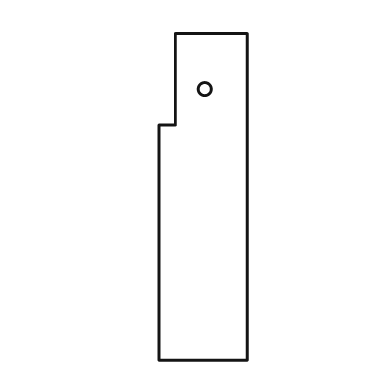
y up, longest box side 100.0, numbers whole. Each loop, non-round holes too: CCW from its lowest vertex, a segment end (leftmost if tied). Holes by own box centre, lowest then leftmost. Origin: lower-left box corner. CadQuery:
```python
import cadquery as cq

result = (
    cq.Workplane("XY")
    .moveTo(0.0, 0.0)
    .lineTo(27.0, 0.0)
    .lineTo(27.0, 100.0)
    .lineTo(5.0, 100.0)
    .lineTo(5.0, 72.0)
    .lineTo(0.0, 72.0)
    .close()
    .moveTo(14.0, 83.0)
    .circle(2.0)
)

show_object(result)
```